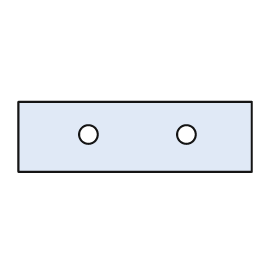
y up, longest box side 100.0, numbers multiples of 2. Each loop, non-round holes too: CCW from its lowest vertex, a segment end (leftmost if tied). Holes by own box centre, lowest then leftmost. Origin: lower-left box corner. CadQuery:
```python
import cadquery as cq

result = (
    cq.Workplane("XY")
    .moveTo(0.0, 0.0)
    .lineTo(100.0, 0.0)
    .lineTo(100.0, 30.0)
    .lineTo(0.0, 30.0)
    .close()
    .moveTo(30.0, 16.0)
    .circle(4.0)
    .moveTo(72.0, 16.0)
    .circle(4.0)
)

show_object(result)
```